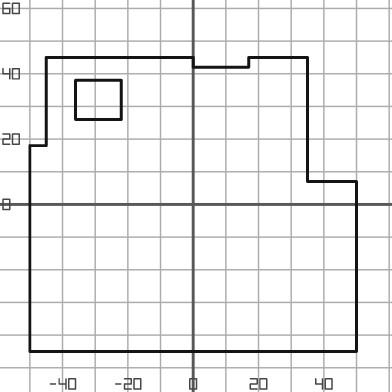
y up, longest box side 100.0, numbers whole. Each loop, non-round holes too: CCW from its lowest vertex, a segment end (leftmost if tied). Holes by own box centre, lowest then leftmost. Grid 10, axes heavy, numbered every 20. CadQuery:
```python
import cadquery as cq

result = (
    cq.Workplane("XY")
    .moveTo(-50.0, -45.0)
    .lineTo(50.0, -45.0)
    .lineTo(50.0, 7.0)
    .lineTo(35.0, 7.0)
    .lineTo(35.0, 45.0)
    .lineTo(17.0, 45.0)
    .lineTo(17.0, 42.0)
    .lineTo(0.0, 42.0)
    .lineTo(0.0, 45.0)
    .lineTo(-45.0, 45.0)
    .lineTo(-45.0, 18.0)
    .lineTo(-50.0, 18.0)
    .close()
    .moveTo(-36.0, 26.0)
    .lineTo(-22.0, 26.0)
    .lineTo(-22.0, 38.0)
    .lineTo(-36.0, 38.0)
    .close()
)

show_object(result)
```